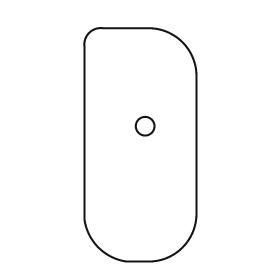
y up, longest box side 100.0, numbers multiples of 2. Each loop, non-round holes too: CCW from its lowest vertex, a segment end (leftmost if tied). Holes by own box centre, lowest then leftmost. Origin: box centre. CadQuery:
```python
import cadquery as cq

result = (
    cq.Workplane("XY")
    .moveTo(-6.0, -50.0)
    .lineTo(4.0, -50.0)
    .threePointArc((18.0, -44.0), (24.0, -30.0))
    .lineTo(24.0, 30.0)
    .threePointArc((18.0, 44.0), (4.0, 50.0))
    .lineTo(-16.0, 50.0)
    .threePointArc((-22.0, 48.0), (-24.0, 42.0))
    .lineTo(-24.0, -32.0)
    .threePointArc((-18.0, -44.0), (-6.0, -50.0))
    .close()
    .moveTo(2.0, 8.0)
    .circle(4.0)
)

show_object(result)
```